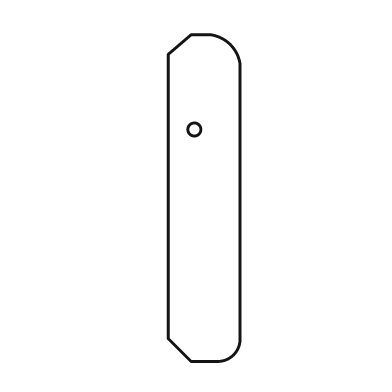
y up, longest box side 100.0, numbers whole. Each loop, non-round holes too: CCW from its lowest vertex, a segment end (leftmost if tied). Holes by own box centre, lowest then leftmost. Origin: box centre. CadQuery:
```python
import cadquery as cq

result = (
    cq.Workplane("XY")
    .moveTo(-4.0, -50.0)
    .lineTo(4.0, -50.0)
    .threePointArc((9.0, -48.0), (11.0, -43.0))
    .lineTo(11.0, 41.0)
    .threePointArc((8.0, 47.0), (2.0, 50.0))
    .lineTo(-4.0, 50.0)
    .lineTo(-11.0, 44.0)
    .lineTo(-11.0, -43.0)
    .close()
    .moveTo(-3.0, 21.0)
    .circle(2.0)
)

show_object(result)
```